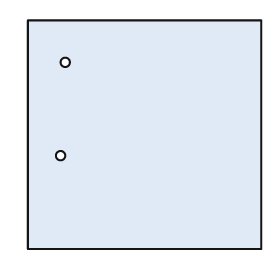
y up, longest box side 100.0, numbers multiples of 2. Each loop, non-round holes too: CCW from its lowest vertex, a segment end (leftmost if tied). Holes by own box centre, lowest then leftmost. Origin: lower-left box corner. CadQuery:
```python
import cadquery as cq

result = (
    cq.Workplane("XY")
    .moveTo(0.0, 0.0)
    .lineTo(100.0, 0.0)
    .lineTo(100.0, 98.0)
    .lineTo(0.0, 98.0)
    .close()
    .moveTo(14.0, 40.0)
    .circle(2.0)
    .moveTo(16.0, 80.0)
    .circle(2.0)
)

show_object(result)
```